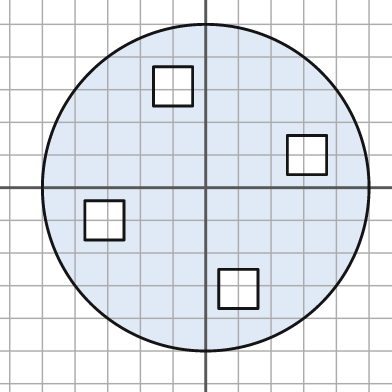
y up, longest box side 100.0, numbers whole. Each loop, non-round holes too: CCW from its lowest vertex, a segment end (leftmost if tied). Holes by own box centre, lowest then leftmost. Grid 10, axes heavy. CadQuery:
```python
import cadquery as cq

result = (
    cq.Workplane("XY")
    .moveTo(0.0, 0.0)
    .circle(50.0)
    .moveTo(4.0, -37.0)
    .lineTo(16.0, -37.0)
    .lineTo(16.0, -25.0)
    .lineTo(4.0, -25.0)
    .close()
    .moveTo(-37.0, -16.0)
    .lineTo(-25.0, -16.0)
    .lineTo(-25.0, -4.0)
    .lineTo(-37.0, -4.0)
    .close()
    .moveTo(25.0, 4.0)
    .lineTo(37.0, 4.0)
    .lineTo(37.0, 16.0)
    .lineTo(25.0, 16.0)
    .close()
    .moveTo(-16.0, 25.0)
    .lineTo(-4.0, 25.0)
    .lineTo(-4.0, 37.0)
    .lineTo(-16.0, 37.0)
    .close()
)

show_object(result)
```